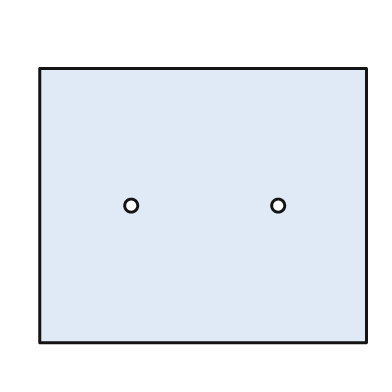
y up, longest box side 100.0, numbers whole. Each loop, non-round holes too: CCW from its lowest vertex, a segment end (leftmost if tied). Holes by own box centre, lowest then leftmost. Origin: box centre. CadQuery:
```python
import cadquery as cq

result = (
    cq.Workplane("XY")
    .moveTo(-50.0, -42.0)
    .lineTo(50.0, -42.0)
    .lineTo(50.0, 42.0)
    .lineTo(-50.0, 42.0)
    .close()
    .moveTo(-22.0, 0.0)
    .circle(2.0)
    .moveTo(23.0, 0.0)
    .circle(2.0)
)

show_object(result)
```